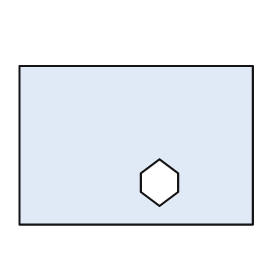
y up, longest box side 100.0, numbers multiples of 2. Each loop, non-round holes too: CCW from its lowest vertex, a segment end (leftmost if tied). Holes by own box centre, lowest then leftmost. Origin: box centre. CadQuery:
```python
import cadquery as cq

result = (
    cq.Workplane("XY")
    .moveTo(-50.0, -34.0)
    .lineTo(50.0, -34.0)
    .lineTo(50.0, 34.0)
    .lineTo(-50.0, 34.0)
    .close()
    .moveTo(10.0, -26.0)
    .lineTo(18.0, -20.0)
    .lineTo(18.0, -12.0)
    .lineTo(10.0, -6.0)
    .lineTo(2.0, -12.0)
    .lineTo(2.0, -20.0)
    .close()
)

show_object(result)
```